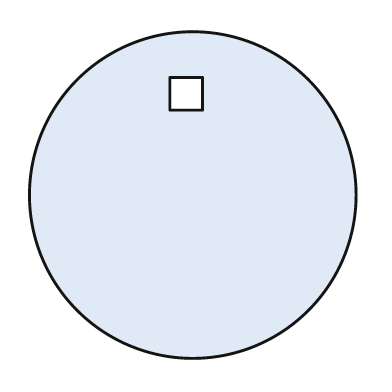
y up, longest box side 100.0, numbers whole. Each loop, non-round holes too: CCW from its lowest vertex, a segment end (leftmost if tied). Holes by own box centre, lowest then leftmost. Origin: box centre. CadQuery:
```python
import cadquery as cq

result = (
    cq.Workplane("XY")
    .moveTo(0.0, 0.0)
    .circle(50.0)
    .moveTo(-7.0, 26.0)
    .lineTo(3.0, 26.0)
    .lineTo(3.0, 36.0)
    .lineTo(-7.0, 36.0)
    .close()
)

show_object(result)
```